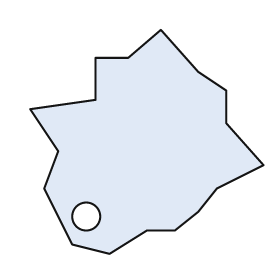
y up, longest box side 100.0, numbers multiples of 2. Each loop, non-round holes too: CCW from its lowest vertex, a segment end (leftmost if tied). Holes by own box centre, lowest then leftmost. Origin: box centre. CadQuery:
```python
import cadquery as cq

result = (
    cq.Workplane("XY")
    .moveTo(-16.0, -48.0)
    .lineTo(0.0, -38.0)
    .lineTo(12.0, -38.0)
    .lineTo(22.0, -30.0)
    .lineTo(30.0, -20.0)
    .lineTo(50.0, -10.0)
    .lineTo(34.0, 8.0)
    .lineTo(34.0, 22.0)
    .lineTo(22.0, 30.0)
    .lineTo(6.0, 48.0)
    .lineTo(-8.0, 36.0)
    .lineTo(-22.0, 36.0)
    .lineTo(-22.0, 18.0)
    .lineTo(-50.0, 14.0)
    .lineTo(-38.0, -4.0)
    .lineTo(-44.0, -20.0)
    .lineTo(-32.0, -44.0)
    .close()
    .moveTo(-26.0, -32.0)
    .circle(6.0)
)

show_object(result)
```